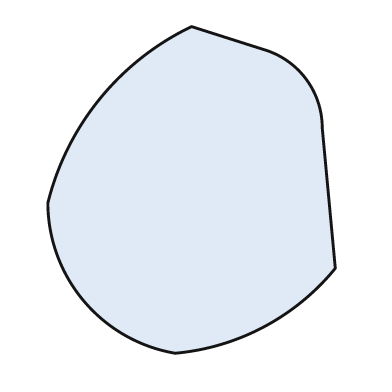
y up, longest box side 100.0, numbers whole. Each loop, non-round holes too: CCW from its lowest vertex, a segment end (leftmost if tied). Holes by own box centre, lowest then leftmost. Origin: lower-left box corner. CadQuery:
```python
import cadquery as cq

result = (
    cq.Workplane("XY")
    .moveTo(39.0, 0.0)
    .threePointArc((66.0, 8.0), (88.0, 26.0))
    .lineTo(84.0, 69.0)
    .threePointArc((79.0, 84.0), (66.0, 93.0))
    .lineTo(44.0, 100.0)
    .threePointArc((16.0, 78.0), (0.0, 46.0))
    .threePointArc((11.0, 16.0), (39.0, 0.0))
    .close()
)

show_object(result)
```